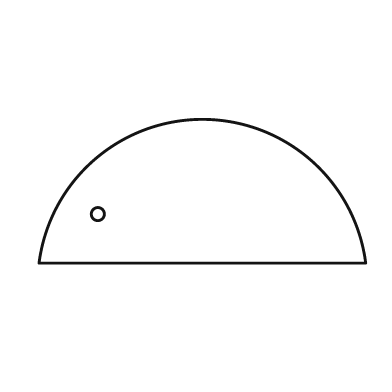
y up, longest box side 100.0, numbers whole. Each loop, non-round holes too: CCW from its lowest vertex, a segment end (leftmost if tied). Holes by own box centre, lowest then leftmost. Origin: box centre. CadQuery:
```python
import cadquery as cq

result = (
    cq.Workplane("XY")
    .moveTo(-50.0, -22.0)
    .lineTo(50.0, -22.0)
    .threePointArc((0.0, 22.0), (-50.0, -22.0))
    .close()
    .moveTo(-32.0, -7.0)
    .circle(2.0)
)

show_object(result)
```